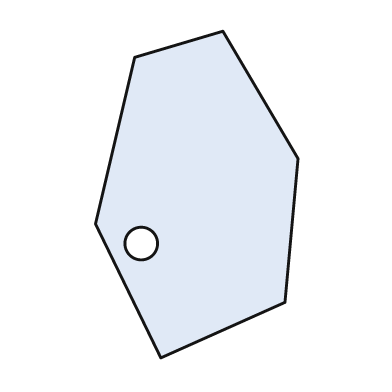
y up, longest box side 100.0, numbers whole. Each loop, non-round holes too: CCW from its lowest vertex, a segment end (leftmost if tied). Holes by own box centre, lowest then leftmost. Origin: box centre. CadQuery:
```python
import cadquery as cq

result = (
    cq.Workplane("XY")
    .moveTo(-11.0, -50.0)
    .lineTo(27.0, -33.0)
    .lineTo(31.0, 11.0)
    .lineTo(8.0, 50.0)
    .lineTo(-19.0, 42.0)
    .lineTo(-31.0, -9.0)
    .close()
    .moveTo(-17.0, -15.0)
    .circle(5.0)
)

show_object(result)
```